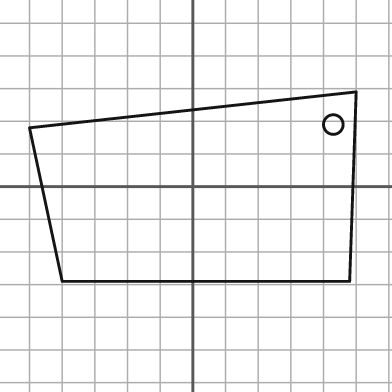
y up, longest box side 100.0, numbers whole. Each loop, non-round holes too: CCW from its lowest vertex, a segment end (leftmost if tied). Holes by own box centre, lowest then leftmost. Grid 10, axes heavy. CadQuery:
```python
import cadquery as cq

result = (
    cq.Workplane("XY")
    .moveTo(-40.0, -29.0)
    .lineTo(48.0, -29.0)
    .lineTo(50.0, 29.0)
    .lineTo(-50.0, 18.0)
    .close()
    .moveTo(43.0, 19.0)
    .circle(3.0)
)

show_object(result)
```